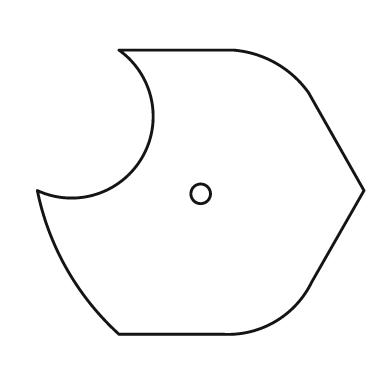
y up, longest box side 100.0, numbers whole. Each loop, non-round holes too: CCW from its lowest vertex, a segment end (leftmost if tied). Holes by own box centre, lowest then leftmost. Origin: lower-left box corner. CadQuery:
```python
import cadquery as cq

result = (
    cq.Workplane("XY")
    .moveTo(25.0, 0.0)
    .lineTo(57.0, 0.0)
    .threePointArc((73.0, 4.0), (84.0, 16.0))
    .lineTo(100.0, 44.0)
    .lineTo(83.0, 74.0)
    .threePointArc((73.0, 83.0), (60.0, 87.0))
    .lineTo(25.0, 87.0)
    .threePointArc((32.0, 54.0), (0.0, 44.0))
    .threePointArc((9.0, 20.0), (25.0, 0.0))
    .close()
    .moveTo(50.0, 43.0)
    .circle(3.0)
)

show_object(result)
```